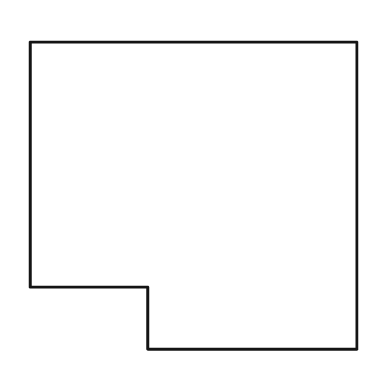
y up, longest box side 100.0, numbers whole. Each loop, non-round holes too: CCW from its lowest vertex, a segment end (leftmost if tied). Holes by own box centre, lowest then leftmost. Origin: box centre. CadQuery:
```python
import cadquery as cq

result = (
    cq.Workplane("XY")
    .moveTo(-14.0, -47.0)
    .lineTo(50.0, -47.0)
    .lineTo(50.0, 47.0)
    .lineTo(-50.0, 47.0)
    .lineTo(-50.0, -28.0)
    .lineTo(-14.0, -28.0)
    .close()
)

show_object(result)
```